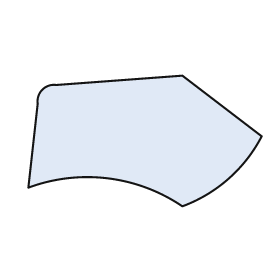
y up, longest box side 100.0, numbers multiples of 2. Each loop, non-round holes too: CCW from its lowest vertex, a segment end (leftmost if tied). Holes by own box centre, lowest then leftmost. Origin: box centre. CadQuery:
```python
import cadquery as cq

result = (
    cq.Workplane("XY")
    .moveTo(16.0, -28.0)
    .threePointArc((36.0, -16.0), (50.0, 2.0))
    .lineTo(16.0, 28.0)
    .lineTo(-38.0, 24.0)
    .threePointArc((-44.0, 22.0), (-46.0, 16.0))
    .lineTo(-50.0, -20.0)
    .threePointArc((-16.0, -16.0), (16.0, -28.0))
    .close()
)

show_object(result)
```